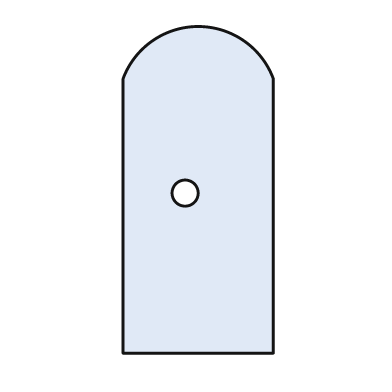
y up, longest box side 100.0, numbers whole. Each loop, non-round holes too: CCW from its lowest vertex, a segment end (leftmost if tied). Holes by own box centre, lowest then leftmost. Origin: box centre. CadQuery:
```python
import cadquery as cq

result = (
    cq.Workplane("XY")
    .moveTo(-23.0, -50.0)
    .lineTo(23.0, -50.0)
    .lineTo(23.0, 34.0)
    .threePointArc((0.0, 50.0), (-23.0, 34.0))
    .close()
    .moveTo(-4.0, -1.0)
    .circle(4.0)
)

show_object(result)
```